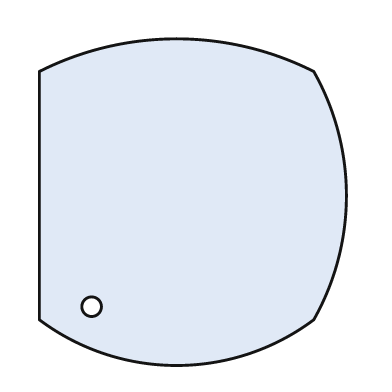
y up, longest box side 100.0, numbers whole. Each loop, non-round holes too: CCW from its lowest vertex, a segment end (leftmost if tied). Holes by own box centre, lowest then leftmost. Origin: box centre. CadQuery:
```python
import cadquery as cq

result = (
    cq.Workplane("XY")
    .moveTo(-47.0, -36.0)
    .threePointArc((-5.0, -50.0), (37.0, -36.0))
    .threePointArc((47.0, 2.0), (37.0, 40.0))
    .threePointArc((-5.0, 50.0), (-47.0, 40.0))
    .close()
    .moveTo(-31.0, -32.0)
    .circle(3.0)
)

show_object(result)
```